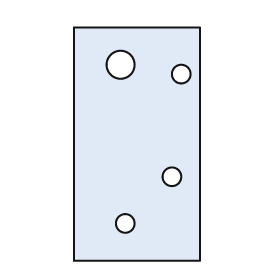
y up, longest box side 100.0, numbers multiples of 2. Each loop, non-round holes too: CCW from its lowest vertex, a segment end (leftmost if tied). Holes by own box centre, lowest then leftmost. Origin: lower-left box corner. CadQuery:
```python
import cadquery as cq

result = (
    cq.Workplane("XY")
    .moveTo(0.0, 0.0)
    .lineTo(54.0, 0.0)
    .lineTo(54.0, 100.0)
    .lineTo(0.0, 100.0)
    .close()
    .moveTo(22.0, 16.0)
    .circle(4.0)
    .moveTo(42.0, 36.0)
    .circle(4.0)
    .moveTo(46.0, 80.0)
    .circle(4.0)
    .moveTo(20.0, 84.0)
    .circle(6.0)
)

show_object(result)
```